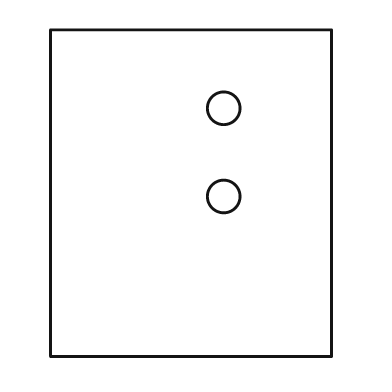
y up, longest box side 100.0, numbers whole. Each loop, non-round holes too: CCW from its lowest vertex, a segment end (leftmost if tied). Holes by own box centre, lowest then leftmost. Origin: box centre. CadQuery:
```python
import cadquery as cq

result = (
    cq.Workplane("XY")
    .moveTo(-43.0, -50.0)
    .lineTo(43.0, -50.0)
    .lineTo(43.0, 50.0)
    .lineTo(-43.0, 50.0)
    .close()
    .moveTo(10.0, -1.0)
    .circle(5.0)
    .moveTo(10.0, 26.0)
    .circle(5.0)
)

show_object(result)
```